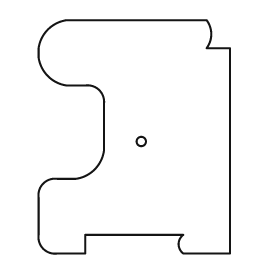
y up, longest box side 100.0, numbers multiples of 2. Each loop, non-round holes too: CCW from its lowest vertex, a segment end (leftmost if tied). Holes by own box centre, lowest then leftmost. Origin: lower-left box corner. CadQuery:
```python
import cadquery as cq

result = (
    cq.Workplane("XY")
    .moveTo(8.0, 0.0)
    .lineTo(20.0, 0.0)
    .lineTo(20.0, 8.0)
    .lineTo(62.0, 8.0)
    .threePointArc((60.0, 4.0), (62.0, 0.0))
    .lineTo(82.0, 0.0)
    .lineTo(82.0, 88.0)
    .lineTo(72.0, 88.0)
    .threePointArc((74.0, 94.0), (72.0, 100.0))
    .lineTo(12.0, 100.0)
    .threePointArc((4.0, 96.0), (0.0, 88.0))
    .lineTo(0.0, 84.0)
    .threePointArc((4.0, 76.0), (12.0, 72.0))
    .lineTo(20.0, 72.0)
    .threePointArc((26.0, 70.0), (28.0, 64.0))
    .lineTo(28.0, 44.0)
    .threePointArc((24.0, 36.0), (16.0, 32.0))
    .lineTo(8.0, 32.0)
    .threePointArc((2.0, 30.0), (0.0, 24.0))
    .lineTo(0.0, 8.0)
    .threePointArc((2.0, 2.0), (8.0, 0.0))
    .close()
    .moveTo(44.0, 48.0)
    .circle(2.0)
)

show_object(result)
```